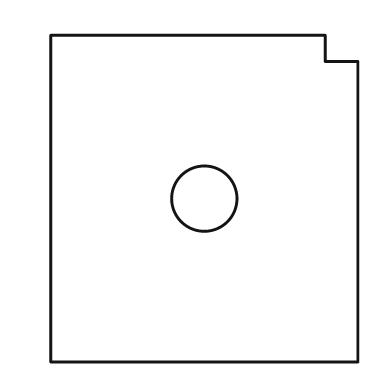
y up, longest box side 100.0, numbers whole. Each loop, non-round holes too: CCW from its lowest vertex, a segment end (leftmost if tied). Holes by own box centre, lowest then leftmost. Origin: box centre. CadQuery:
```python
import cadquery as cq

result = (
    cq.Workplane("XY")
    .moveTo(-47.0, -50.0)
    .lineTo(47.0, -50.0)
    .lineTo(47.0, 42.0)
    .lineTo(37.0, 42.0)
    .lineTo(37.0, 50.0)
    .lineTo(-47.0, 50.0)
    .close()
    .moveTo(0.0, 0.0)
    .circle(10.0)
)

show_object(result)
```